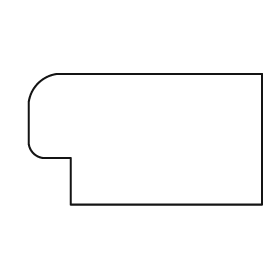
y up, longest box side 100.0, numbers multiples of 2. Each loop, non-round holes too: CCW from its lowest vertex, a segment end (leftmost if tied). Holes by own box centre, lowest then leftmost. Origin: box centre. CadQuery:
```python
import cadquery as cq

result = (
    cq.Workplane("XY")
    .moveTo(-32.0, -28.0)
    .lineTo(50.0, -28.0)
    .lineTo(50.0, 28.0)
    .lineTo(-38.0, 28.0)
    .threePointArc((-46.0, 24.0), (-50.0, 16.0))
    .lineTo(-50.0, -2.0)
    .threePointArc((-48.0, -6.0), (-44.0, -8.0))
    .lineTo(-32.0, -8.0)
    .close()
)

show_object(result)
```